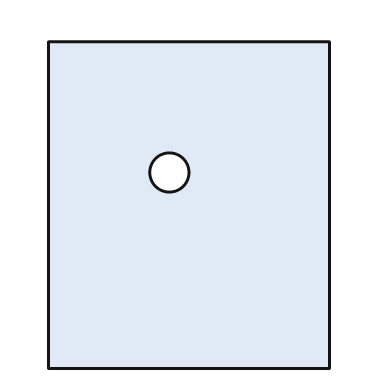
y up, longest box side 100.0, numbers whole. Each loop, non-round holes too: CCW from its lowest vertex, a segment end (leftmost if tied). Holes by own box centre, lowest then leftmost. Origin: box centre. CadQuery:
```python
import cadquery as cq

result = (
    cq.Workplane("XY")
    .moveTo(-43.0, -50.0)
    .lineTo(43.0, -50.0)
    .lineTo(43.0, 50.0)
    .lineTo(-43.0, 50.0)
    .close()
    .moveTo(-6.0, 10.0)
    .circle(6.0)
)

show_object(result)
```